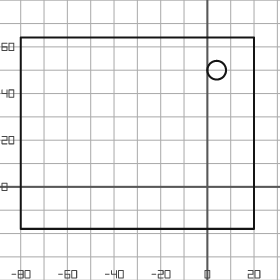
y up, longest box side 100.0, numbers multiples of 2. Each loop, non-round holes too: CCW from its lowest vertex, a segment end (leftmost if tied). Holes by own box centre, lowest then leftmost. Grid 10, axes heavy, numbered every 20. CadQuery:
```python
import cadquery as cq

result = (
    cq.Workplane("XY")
    .moveTo(-80.0, -18.0)
    .lineTo(20.0, -18.0)
    .lineTo(20.0, 64.0)
    .lineTo(-80.0, 64.0)
    .close()
    .moveTo(4.0, 50.0)
    .circle(4.0)
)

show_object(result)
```